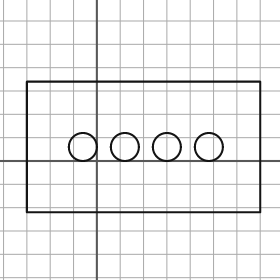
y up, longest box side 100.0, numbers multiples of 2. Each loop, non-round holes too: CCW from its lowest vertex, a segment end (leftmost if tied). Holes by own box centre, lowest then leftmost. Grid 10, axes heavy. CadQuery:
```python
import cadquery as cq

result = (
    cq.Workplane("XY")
    .moveTo(-30.0, -22.0)
    .lineTo(70.0, -22.0)
    .lineTo(70.0, 34.0)
    .lineTo(-30.0, 34.0)
    .close()
    .moveTo(-6.0, 6.0)
    .circle(6.0)
    .moveTo(12.0, 6.0)
    .circle(6.0)
    .moveTo(30.0, 6.0)
    .circle(6.0)
    .moveTo(48.0, 6.0)
    .circle(6.0)
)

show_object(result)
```